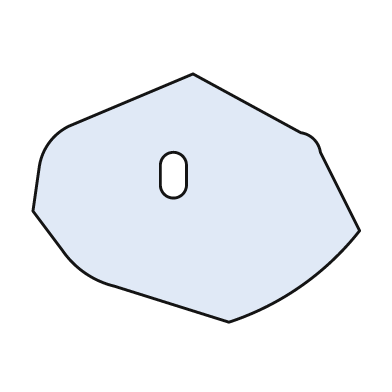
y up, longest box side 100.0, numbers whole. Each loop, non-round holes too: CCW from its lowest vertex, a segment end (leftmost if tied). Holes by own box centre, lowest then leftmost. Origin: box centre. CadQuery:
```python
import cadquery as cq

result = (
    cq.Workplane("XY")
    .moveTo(10.0, -38.0)
    .threePointArc((32.0, -27.0), (50.0, -10.0))
    .lineTo(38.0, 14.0)
    .threePointArc((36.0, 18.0), (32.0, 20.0))
    .lineTo(-1.0, 38.0)
    .lineTo(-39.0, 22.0)
    .threePointArc((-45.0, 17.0), (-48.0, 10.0))
    .lineTo(-50.0, -4.0)
    .lineTo(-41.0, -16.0)
    .threePointArc((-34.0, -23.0), (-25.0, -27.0))
    .close()
    .moveTo(-11.0, 4.0)
    .threePointArc((-7.0, 0.0), (-3.0, 4.0))
    .lineTo(-3.0, 10.0)
    .threePointArc((-7.0, 14.0), (-11.0, 10.0))
    .close()
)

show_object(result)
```